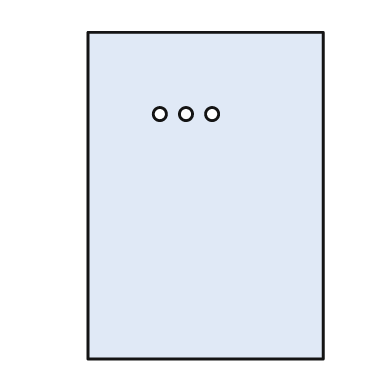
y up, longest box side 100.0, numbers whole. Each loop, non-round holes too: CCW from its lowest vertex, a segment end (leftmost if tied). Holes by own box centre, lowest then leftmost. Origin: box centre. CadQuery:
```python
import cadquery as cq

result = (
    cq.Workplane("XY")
    .moveTo(-36.0, -50.0)
    .lineTo(36.0, -50.0)
    .lineTo(36.0, 50.0)
    .lineTo(-36.0, 50.0)
    .close()
    .moveTo(-14.0, 25.0)
    .circle(2.0)
    .moveTo(-6.0, 25.0)
    .circle(2.0)
    .moveTo(2.0, 25.0)
    .circle(2.0)
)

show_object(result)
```